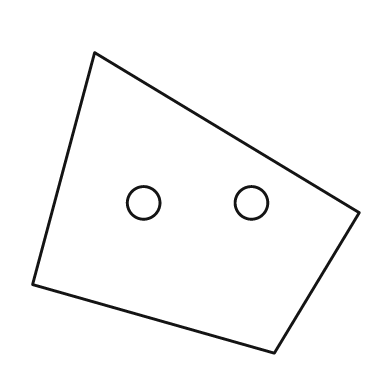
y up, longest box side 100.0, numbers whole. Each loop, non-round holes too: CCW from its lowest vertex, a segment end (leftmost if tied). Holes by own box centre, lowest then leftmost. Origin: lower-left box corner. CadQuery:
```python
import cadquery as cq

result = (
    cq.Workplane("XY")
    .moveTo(74.0, 0.0)
    .lineTo(100.0, 43.0)
    .lineTo(19.0, 92.0)
    .lineTo(0.0, 21.0)
    .close()
    .moveTo(34.0, 46.0)
    .circle(5.0)
    .moveTo(67.0, 46.0)
    .circle(5.0)
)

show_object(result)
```